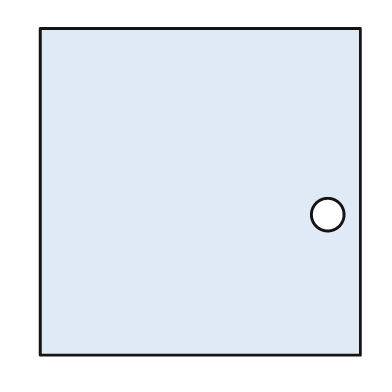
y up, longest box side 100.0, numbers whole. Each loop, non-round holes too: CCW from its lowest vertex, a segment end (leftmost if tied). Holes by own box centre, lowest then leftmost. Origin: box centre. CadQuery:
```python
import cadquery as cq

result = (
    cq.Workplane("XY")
    .moveTo(-49.0, -50.0)
    .lineTo(49.0, -50.0)
    .lineTo(49.0, 50.0)
    .lineTo(-49.0, 50.0)
    .close()
    .moveTo(39.0, -7.0)
    .circle(5.0)
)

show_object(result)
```